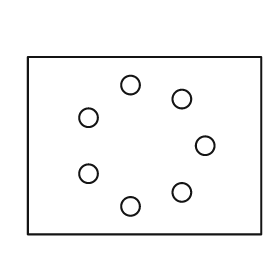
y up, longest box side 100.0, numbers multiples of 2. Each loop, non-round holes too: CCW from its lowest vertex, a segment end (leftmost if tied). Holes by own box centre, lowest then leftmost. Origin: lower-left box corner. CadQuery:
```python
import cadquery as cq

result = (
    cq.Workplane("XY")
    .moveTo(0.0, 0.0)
    .lineTo(100.0, 0.0)
    .lineTo(100.0, 76.0)
    .lineTo(0.0, 76.0)
    .close()
    .moveTo(44.0, 12.0)
    .circle(4.0)
    .moveTo(66.0, 18.0)
    .circle(4.0)
    .moveTo(26.0, 26.0)
    .circle(4.0)
    .moveTo(76.0, 38.0)
    .circle(4.0)
    .moveTo(26.0, 50.0)
    .circle(4.0)
    .moveTo(66.0, 58.0)
    .circle(4.0)
    .moveTo(44.0, 64.0)
    .circle(4.0)
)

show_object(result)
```